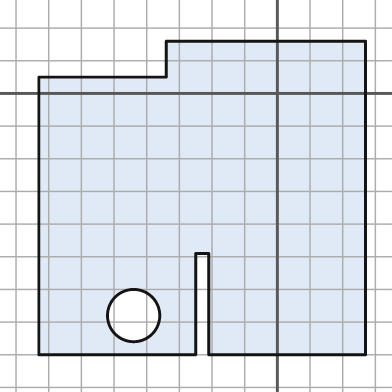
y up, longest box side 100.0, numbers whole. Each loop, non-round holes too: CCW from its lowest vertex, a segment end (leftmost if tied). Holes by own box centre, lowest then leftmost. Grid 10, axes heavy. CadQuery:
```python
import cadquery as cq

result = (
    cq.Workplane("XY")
    .moveTo(-73.0, -80.0)
    .lineTo(-25.0, -80.0)
    .lineTo(-25.0, -49.0)
    .lineTo(-21.0, -49.0)
    .lineTo(-21.0, -80.0)
    .lineTo(27.0, -80.0)
    .lineTo(27.0, 16.0)
    .lineTo(-34.0, 16.0)
    .lineTo(-34.0, 5.0)
    .lineTo(-73.0, 5.0)
    .close()
    .moveTo(-44.0, -68.0)
    .circle(8.0)
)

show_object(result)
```